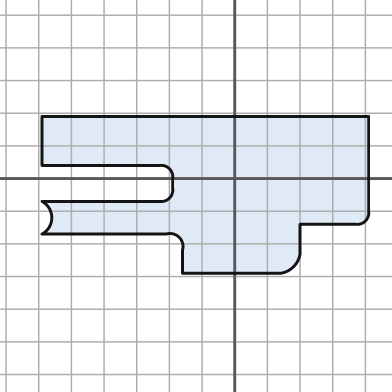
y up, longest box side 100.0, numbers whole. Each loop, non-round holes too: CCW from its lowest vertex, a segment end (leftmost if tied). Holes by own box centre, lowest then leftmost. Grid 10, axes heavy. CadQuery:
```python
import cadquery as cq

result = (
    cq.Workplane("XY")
    .moveTo(-16.0, -29.0)
    .lineTo(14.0, -29.0)
    .threePointArc((18.0, -27.0), (20.0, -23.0))
    .lineTo(20.0, -14.0)
    .lineTo(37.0, -14.0)
    .threePointArc((40.0, -13.0), (41.0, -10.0))
    .lineTo(41.0, 19.0)
    .lineTo(-59.0, 19.0)
    .lineTo(-59.0, 4.0)
    .lineTo(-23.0, 4.0)
    .threePointArc((-20.0, 3.0), (-19.0, 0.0))
    .lineTo(-19.0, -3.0)
    .threePointArc((-20.0, -6.0), (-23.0, -7.0))
    .lineTo(-59.0, -7.0)
    .threePointArc((-56.0, -12.0), (-59.0, -17.0))
    .lineTo(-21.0, -17.0)
    .threePointArc((-17.0, -18.0), (-16.0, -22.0))
    .close()
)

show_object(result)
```